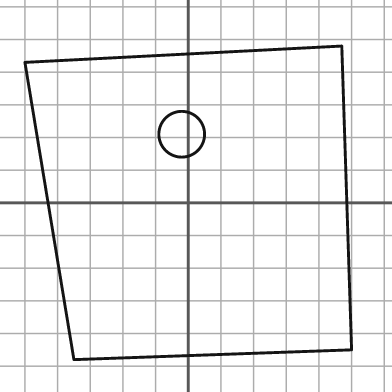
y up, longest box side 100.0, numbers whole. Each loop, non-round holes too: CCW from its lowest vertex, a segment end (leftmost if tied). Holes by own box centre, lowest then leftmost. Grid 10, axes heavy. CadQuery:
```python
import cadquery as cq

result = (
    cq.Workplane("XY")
    .moveTo(-35.0, -48.0)
    .lineTo(50.0, -45.0)
    .lineTo(47.0, 48.0)
    .lineTo(-50.0, 43.0)
    .close()
    .moveTo(-2.0, 21.0)
    .circle(7.0)
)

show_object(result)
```